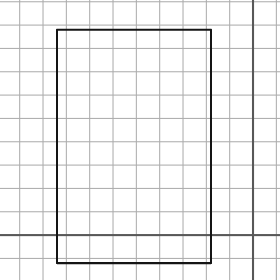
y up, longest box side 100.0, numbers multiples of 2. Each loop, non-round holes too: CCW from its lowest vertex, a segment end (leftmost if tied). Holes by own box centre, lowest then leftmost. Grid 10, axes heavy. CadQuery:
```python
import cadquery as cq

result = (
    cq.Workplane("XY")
    .moveTo(-84.0, -12.0)
    .lineTo(-18.0, -12.0)
    .lineTo(-18.0, 88.0)
    .lineTo(-84.0, 88.0)
    .close()
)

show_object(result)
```